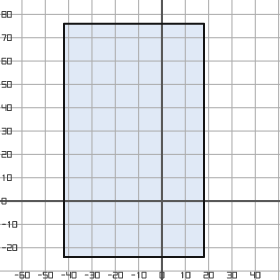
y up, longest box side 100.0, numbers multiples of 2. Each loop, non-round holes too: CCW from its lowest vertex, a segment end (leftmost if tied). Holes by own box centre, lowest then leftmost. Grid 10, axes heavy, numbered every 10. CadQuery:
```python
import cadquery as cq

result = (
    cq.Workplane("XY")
    .moveTo(-42.0, -24.0)
    .lineTo(18.0, -24.0)
    .lineTo(18.0, 76.0)
    .lineTo(-42.0, 76.0)
    .close()
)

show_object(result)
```